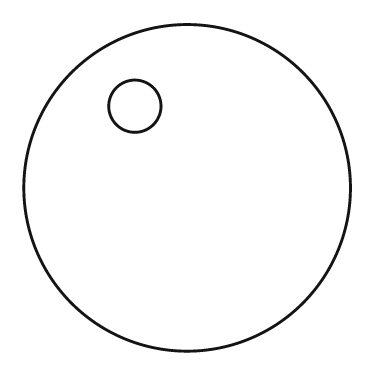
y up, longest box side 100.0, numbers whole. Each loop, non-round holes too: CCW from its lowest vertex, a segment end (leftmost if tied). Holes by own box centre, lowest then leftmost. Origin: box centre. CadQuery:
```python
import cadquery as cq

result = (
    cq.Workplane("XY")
    .moveTo(0.0, 0.0)
    .circle(50.0)
    .moveTo(-16.0, 25.0)
    .circle(8.0)
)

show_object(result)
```